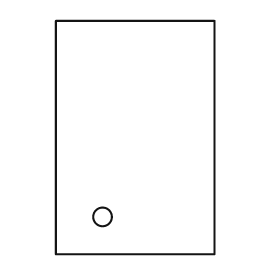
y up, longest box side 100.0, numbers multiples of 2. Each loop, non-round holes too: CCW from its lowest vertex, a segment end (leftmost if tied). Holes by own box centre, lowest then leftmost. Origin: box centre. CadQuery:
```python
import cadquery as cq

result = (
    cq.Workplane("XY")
    .moveTo(-34.0, -50.0)
    .lineTo(34.0, -50.0)
    .lineTo(34.0, 50.0)
    .lineTo(-34.0, 50.0)
    .close()
    .moveTo(-14.0, -34.0)
    .circle(4.0)
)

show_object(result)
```